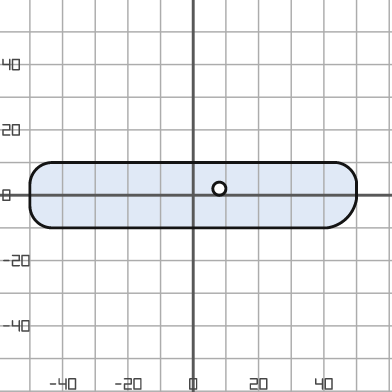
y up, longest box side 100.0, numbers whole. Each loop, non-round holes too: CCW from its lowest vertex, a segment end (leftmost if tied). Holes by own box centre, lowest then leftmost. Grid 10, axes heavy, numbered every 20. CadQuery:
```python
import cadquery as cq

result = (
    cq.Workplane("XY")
    .moveTo(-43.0, -10.0)
    .lineTo(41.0, -10.0)
    .threePointArc((47.0, -7.0), (50.0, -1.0))
    .lineTo(50.0, 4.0)
    .threePointArc((48.0, 8.0), (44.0, 10.0))
    .lineTo(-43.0, 10.0)
    .threePointArc((-48.0, 8.0), (-50.0, 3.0))
    .lineTo(-50.0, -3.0)
    .threePointArc((-48.0, -8.0), (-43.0, -10.0))
    .close()
    .moveTo(8.0, 2.0)
    .circle(2.0)
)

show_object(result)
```